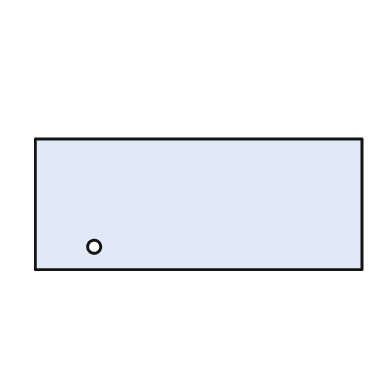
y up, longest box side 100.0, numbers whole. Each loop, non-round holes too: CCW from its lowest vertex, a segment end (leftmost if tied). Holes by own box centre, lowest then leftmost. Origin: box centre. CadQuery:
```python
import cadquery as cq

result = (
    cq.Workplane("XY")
    .moveTo(-50.0, -20.0)
    .lineTo(50.0, -20.0)
    .lineTo(50.0, 20.0)
    .lineTo(-50.0, 20.0)
    .close()
    .moveTo(-32.0, -13.0)
    .circle(2.0)
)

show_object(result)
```